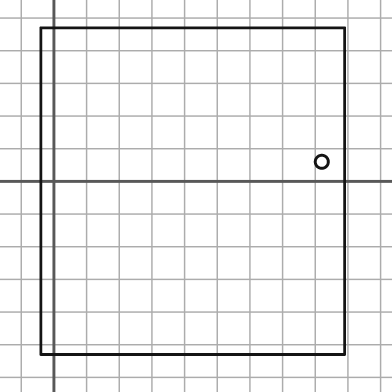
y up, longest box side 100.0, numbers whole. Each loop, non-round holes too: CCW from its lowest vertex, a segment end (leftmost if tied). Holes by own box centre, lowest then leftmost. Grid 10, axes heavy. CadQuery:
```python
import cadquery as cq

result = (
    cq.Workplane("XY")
    .moveTo(-4.0, -53.0)
    .lineTo(89.0, -53.0)
    .lineTo(89.0, 47.0)
    .lineTo(-4.0, 47.0)
    .close()
    .moveTo(82.0, 6.0)
    .circle(2.0)
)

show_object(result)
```